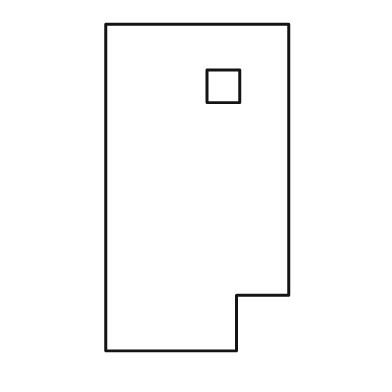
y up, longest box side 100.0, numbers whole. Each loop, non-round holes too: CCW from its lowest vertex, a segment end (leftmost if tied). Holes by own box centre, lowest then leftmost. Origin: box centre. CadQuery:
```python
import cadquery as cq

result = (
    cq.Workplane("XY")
    .moveTo(-28.0, -50.0)
    .lineTo(12.0, -50.0)
    .lineTo(12.0, -33.0)
    .lineTo(28.0, -33.0)
    .lineTo(28.0, 50.0)
    .lineTo(-28.0, 50.0)
    .close()
    .moveTo(3.0, 26.0)
    .lineTo(13.0, 26.0)
    .lineTo(13.0, 36.0)
    .lineTo(3.0, 36.0)
    .close()
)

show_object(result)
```